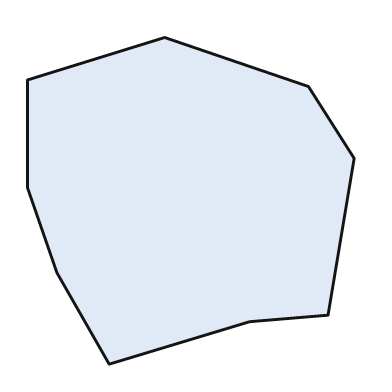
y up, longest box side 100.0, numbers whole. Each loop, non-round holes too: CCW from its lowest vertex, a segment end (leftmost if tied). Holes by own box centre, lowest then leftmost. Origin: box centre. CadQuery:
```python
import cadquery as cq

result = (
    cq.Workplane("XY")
    .moveTo(-25.0, -50.0)
    .lineTo(18.0, -37.0)
    .lineTo(42.0, -35.0)
    .lineTo(50.0, 13.0)
    .lineTo(36.0, 35.0)
    .lineTo(-8.0, 50.0)
    .lineTo(-50.0, 37.0)
    .lineTo(-50.0, 4.0)
    .lineTo(-41.0, -22.0)
    .close()
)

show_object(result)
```